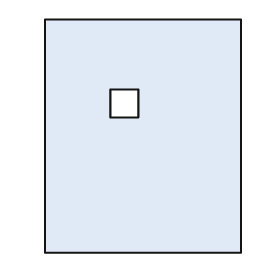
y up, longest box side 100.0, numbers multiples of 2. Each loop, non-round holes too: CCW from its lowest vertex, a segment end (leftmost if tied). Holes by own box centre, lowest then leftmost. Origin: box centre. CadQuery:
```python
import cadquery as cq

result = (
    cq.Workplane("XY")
    .moveTo(-42.0, -50.0)
    .lineTo(42.0, -50.0)
    .lineTo(42.0, 50.0)
    .lineTo(-42.0, 50.0)
    .close()
    .moveTo(-14.0, 8.0)
    .lineTo(-2.0, 8.0)
    .lineTo(-2.0, 20.0)
    .lineTo(-14.0, 20.0)
    .close()
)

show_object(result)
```